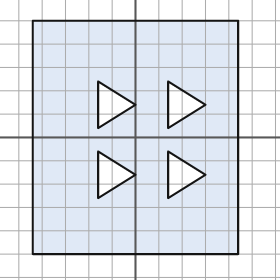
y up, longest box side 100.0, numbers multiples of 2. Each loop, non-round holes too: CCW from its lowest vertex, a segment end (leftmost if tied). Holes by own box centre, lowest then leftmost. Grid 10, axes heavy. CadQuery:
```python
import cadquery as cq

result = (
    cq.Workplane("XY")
    .moveTo(-44.0, -50.0)
    .lineTo(44.0, -50.0)
    .lineTo(44.0, 50.0)
    .lineTo(-44.0, 50.0)
    .close()
    .moveTo(-16.0, -26.0)
    .lineTo(0.0, -16.0)
    .lineTo(-16.0, -6.0)
    .close()
    .moveTo(14.0, -26.0)
    .lineTo(30.0, -16.0)
    .lineTo(14.0, -6.0)
    .close()
    .moveTo(-16.0, 4.0)
    .lineTo(0.0, 14.0)
    .lineTo(-16.0, 24.0)
    .close()
    .moveTo(14.0, 4.0)
    .lineTo(30.0, 14.0)
    .lineTo(14.0, 24.0)
    .close()
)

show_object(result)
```